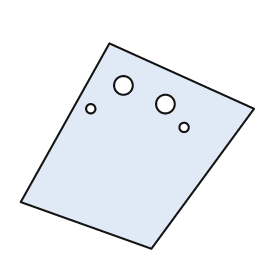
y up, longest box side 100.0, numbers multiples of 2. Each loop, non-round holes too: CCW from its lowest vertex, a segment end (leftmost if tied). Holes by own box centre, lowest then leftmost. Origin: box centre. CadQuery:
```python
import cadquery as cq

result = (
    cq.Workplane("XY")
    .moveTo(6.0, -44.0)
    .lineTo(50.0, 16.0)
    .lineTo(-12.0, 44.0)
    .lineTo(-50.0, -24.0)
    .close()
    .moveTo(20.0, 8.0)
    .circle(2.0)
    .moveTo(-20.0, 16.0)
    .circle(2.0)
    .moveTo(12.0, 18.0)
    .circle(4.0)
    .moveTo(-6.0, 26.0)
    .circle(4.0)
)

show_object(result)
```